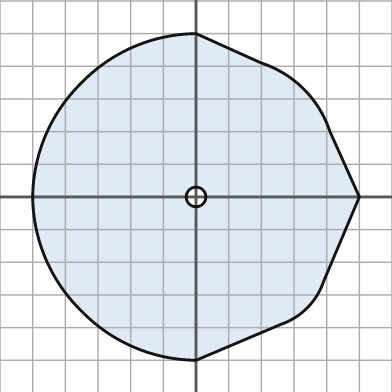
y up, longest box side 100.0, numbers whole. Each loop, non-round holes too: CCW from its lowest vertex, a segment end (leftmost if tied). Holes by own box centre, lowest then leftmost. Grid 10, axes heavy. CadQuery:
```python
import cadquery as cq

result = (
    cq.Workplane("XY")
    .moveTo(0.0, -50.0)
    .lineTo(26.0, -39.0)
    .threePointArc((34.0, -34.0), (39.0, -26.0))
    .lineTo(50.0, 0.0)
    .lineTo(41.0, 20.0)
    .threePointArc((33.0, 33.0), (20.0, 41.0))
    .lineTo(0.0, 50.0)
    .threePointArc((-19.0, 46.0), (-35.0, 35.0))
    .threePointArc((-46.0, 19.0), (-50.0, 0.0))
    .threePointArc((-46.0, -19.0), (-35.0, -35.0))
    .threePointArc((-19.0, -46.0), (0.0, -50.0))
    .close()
    .moveTo(0.0, 0.0)
    .circle(3.0)
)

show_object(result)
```